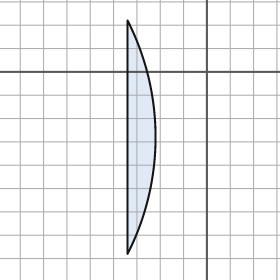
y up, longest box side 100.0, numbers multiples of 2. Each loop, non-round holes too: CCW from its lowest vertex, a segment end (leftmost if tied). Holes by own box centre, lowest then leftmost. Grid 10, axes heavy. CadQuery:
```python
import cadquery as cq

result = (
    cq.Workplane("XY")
    .moveTo(-34.0, -78.0)
    .threePointArc((-22.0, -28.0), (-34.0, 22.0))
    .close()
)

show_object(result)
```